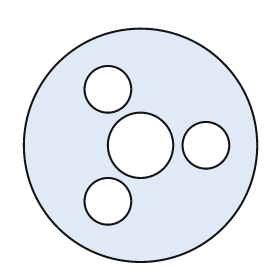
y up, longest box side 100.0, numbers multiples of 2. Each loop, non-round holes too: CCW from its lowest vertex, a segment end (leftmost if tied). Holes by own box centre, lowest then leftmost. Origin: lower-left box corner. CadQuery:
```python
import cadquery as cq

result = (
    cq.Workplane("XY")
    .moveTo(50.0, 50.0)
    .circle(50.0)
    .moveTo(36.0, 26.0)
    .circle(10.0)
    .moveTo(50.0, 50.0)
    .circle(14.0)
    .moveTo(78.0, 50.0)
    .circle(10.0)
    .moveTo(36.0, 74.0)
    .circle(10.0)
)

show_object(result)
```